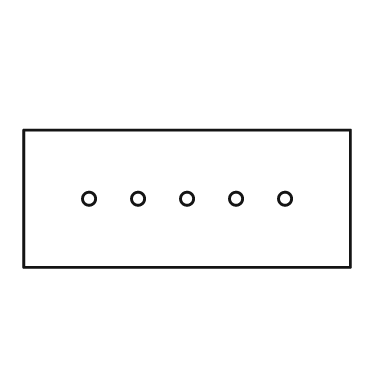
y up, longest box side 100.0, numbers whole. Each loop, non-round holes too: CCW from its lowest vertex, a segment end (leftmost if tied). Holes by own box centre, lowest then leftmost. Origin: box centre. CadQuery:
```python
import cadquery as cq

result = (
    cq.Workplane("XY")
    .moveTo(-50.0, -21.0)
    .lineTo(50.0, -21.0)
    .lineTo(50.0, 21.0)
    .lineTo(-50.0, 21.0)
    .close()
    .moveTo(-30.0, 0.0)
    .circle(2.0)
    .moveTo(-15.0, 0.0)
    .circle(2.0)
    .moveTo(0.0, 0.0)
    .circle(2.0)
    .moveTo(15.0, 0.0)
    .circle(2.0)
    .moveTo(30.0, 0.0)
    .circle(2.0)
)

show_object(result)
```